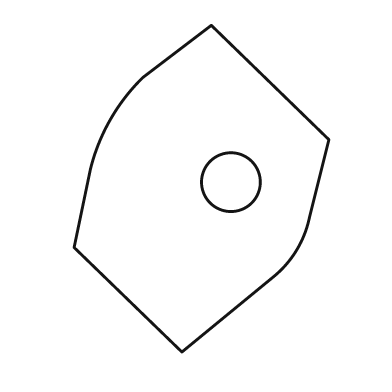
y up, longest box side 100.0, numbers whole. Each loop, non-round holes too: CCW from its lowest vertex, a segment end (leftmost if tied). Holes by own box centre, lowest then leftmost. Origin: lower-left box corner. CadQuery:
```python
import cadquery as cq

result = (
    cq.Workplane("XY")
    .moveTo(33.0, 0.0)
    .lineTo(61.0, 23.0)
    .threePointArc((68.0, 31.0), (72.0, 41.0))
    .lineTo(78.0, 65.0)
    .lineTo(42.0, 100.0)
    .lineTo(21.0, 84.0)
    .threePointArc((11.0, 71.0), (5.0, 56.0))
    .lineTo(0.0, 32.0)
    .close()
    .moveTo(48.0, 52.0)
    .circle(9.0)
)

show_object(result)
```